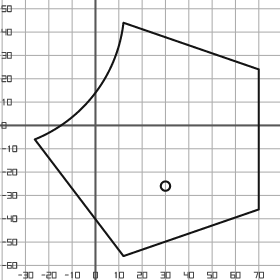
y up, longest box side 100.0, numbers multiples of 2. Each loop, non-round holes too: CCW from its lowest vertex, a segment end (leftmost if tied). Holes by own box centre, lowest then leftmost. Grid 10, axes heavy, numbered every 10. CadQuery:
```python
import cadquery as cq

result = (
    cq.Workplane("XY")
    .moveTo(12.0, -56.0)
    .lineTo(70.0, -36.0)
    .lineTo(70.0, 24.0)
    .lineTo(12.0, 44.0)
    .threePointArc((0.0, 14.0), (-26.0, -6.0))
    .close()
    .moveTo(30.0, -26.0)
    .circle(2.0)
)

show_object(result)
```